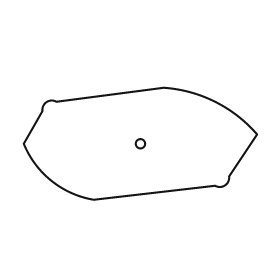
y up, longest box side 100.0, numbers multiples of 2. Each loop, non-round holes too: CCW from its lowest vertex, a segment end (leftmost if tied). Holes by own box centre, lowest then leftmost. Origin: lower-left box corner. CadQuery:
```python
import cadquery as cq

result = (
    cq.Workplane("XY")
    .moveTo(30.0, 0.0)
    .lineTo(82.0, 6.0)
    .threePointArc((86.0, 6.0), (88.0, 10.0))
    .lineTo(100.0, 28.0)
    .threePointArc((82.0, 42.0), (60.0, 48.0))
    .lineTo(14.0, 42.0)
    .threePointArc((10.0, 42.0), (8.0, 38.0))
    .lineTo(0.0, 24.0)
    .threePointArc((12.0, 8.0), (30.0, 0.0))
    .close()
    .moveTo(50.0, 24.0)
    .circle(2.0)
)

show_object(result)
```